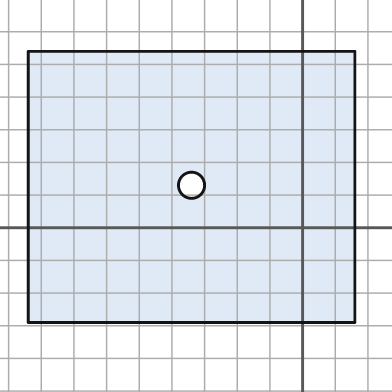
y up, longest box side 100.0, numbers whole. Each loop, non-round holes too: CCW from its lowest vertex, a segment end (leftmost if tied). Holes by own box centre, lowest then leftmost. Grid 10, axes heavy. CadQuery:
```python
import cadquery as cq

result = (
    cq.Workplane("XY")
    .moveTo(-84.0, -29.0)
    .lineTo(16.0, -29.0)
    .lineTo(16.0, 54.0)
    .lineTo(-84.0, 54.0)
    .close()
    .moveTo(-34.0, 13.0)
    .circle(4.0)
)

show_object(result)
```